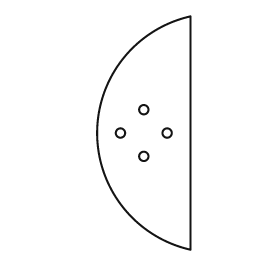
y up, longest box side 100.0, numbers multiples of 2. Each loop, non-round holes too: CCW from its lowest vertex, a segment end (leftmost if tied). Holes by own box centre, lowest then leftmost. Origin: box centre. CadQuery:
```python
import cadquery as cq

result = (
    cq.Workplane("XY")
    .moveTo(20.0, -50.0)
    .lineTo(20.0, 50.0)
    .threePointArc((-20.0, 0.0), (20.0, -50.0))
    .close()
    .moveTo(0.0, -10.0)
    .circle(2.0)
    .moveTo(-10.0, 0.0)
    .circle(2.0)
    .moveTo(10.0, 0.0)
    .circle(2.0)
    .moveTo(0.0, 10.0)
    .circle(2.0)
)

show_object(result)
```